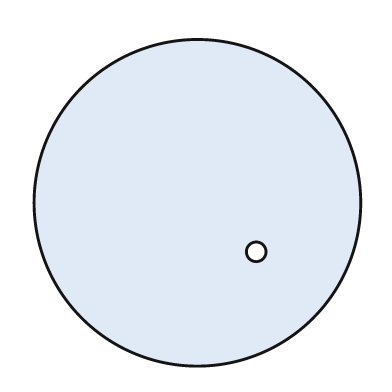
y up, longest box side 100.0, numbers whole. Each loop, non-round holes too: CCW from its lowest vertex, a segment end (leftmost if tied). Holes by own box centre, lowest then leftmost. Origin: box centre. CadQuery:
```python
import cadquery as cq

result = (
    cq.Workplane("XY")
    .moveTo(0.0, 0.0)
    .circle(50.0)
    .moveTo(18.0, -15.0)
    .circle(3.0)
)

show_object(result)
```